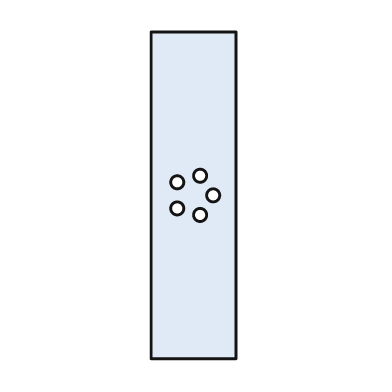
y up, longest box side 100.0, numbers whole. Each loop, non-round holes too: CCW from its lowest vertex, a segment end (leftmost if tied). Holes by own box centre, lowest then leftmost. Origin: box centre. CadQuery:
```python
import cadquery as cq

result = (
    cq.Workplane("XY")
    .moveTo(-13.0, -50.0)
    .lineTo(13.0, -50.0)
    .lineTo(13.0, 50.0)
    .lineTo(-13.0, 50.0)
    .close()
    .moveTo(2.0, -6.0)
    .circle(2.0)
    .moveTo(-5.0, -4.0)
    .circle(2.0)
    .moveTo(6.0, 0.0)
    .circle(2.0)
    .moveTo(-5.0, 4.0)
    .circle(2.0)
    .moveTo(2.0, 6.0)
    .circle(2.0)
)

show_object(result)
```